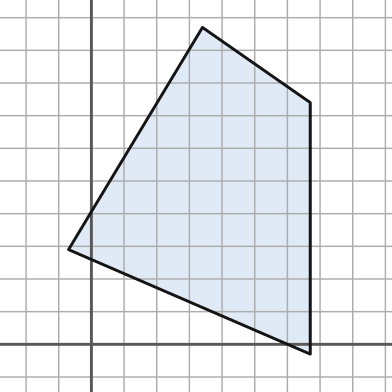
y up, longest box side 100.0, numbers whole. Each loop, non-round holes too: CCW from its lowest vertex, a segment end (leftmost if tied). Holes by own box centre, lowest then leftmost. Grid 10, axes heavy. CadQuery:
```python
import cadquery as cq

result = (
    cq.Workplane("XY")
    .moveTo(67.0, -3.0)
    .lineTo(67.0, 74.0)
    .lineTo(34.0, 97.0)
    .lineTo(-7.0, 29.0)
    .close()
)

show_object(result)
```